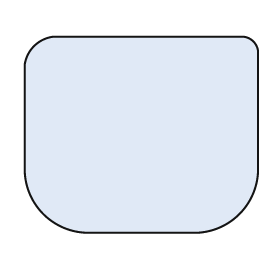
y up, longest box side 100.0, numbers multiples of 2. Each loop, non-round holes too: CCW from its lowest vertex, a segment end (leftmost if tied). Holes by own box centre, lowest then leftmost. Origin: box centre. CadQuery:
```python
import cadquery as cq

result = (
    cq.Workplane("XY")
    .moveTo(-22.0, -42.0)
    .lineTo(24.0, -42.0)
    .threePointArc((42.0, -34.0), (50.0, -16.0))
    .lineTo(50.0, 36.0)
    .threePointArc((48.0, 40.0), (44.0, 42.0))
    .lineTo(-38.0, 42.0)
    .threePointArc((-46.0, 38.0), (-50.0, 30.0))
    .lineTo(-50.0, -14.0)
    .threePointArc((-42.0, -34.0), (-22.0, -42.0))
    .close()
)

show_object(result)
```